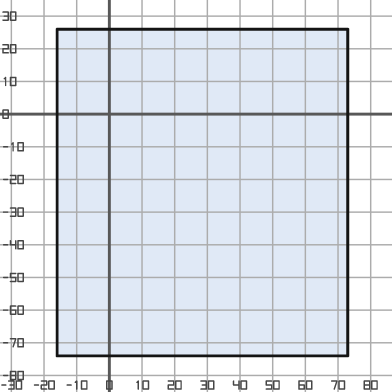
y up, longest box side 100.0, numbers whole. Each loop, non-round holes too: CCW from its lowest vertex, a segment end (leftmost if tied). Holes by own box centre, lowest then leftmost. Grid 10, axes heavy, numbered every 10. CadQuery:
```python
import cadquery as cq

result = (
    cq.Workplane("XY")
    .moveTo(-16.0, -74.0)
    .lineTo(73.0, -74.0)
    .lineTo(73.0, 26.0)
    .lineTo(-16.0, 26.0)
    .close()
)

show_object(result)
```